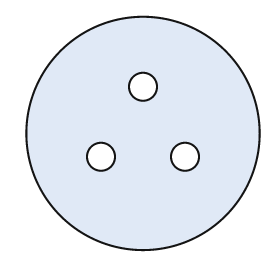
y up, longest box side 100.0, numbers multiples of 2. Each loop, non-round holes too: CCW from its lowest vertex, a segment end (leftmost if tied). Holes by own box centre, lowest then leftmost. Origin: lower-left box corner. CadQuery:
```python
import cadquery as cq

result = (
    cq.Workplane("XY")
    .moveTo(50.0, 50.0)
    .circle(50.0)
    .moveTo(32.0, 40.0)
    .circle(6.0)
    .moveTo(68.0, 40.0)
    .circle(6.0)
    .moveTo(50.0, 70.0)
    .circle(6.0)
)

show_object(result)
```